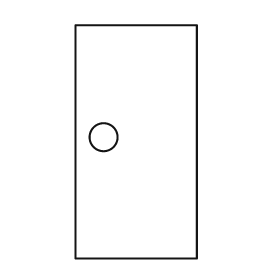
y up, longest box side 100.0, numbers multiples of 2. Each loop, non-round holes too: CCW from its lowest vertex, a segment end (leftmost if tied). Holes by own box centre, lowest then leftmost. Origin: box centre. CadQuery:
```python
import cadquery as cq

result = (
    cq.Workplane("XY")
    .moveTo(-26.0, -50.0)
    .lineTo(26.0, -50.0)
    .lineTo(26.0, 50.0)
    .lineTo(-26.0, 50.0)
    .close()
    .moveTo(-14.0, 2.0)
    .circle(6.0)
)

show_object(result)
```